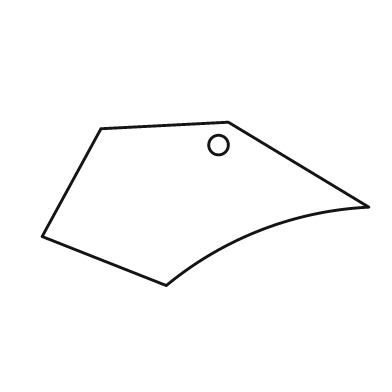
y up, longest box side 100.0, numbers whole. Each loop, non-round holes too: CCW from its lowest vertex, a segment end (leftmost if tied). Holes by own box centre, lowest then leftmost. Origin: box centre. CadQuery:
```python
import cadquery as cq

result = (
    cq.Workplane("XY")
    .moveTo(-12.0, -25.0)
    .threePointArc((17.0, -8.0), (50.0, -1.0))
    .lineTo(7.0, 25.0)
    .lineTo(-32.0, 23.0)
    .lineTo(-50.0, -10.0)
    .close()
    .moveTo(4.0, 18.0)
    .circle(3.0)
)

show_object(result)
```